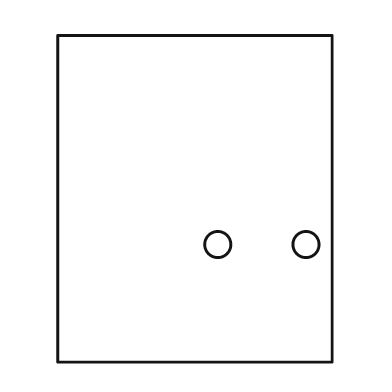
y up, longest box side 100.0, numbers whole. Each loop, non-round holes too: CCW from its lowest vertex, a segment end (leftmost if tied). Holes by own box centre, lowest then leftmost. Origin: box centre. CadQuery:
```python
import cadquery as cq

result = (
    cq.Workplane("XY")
    .moveTo(-42.0, -50.0)
    .lineTo(42.0, -50.0)
    .lineTo(42.0, 50.0)
    .lineTo(-42.0, 50.0)
    .close()
    .moveTo(7.0, -14.0)
    .circle(4.0)
    .moveTo(34.0, -14.0)
    .circle(4.0)
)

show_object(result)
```